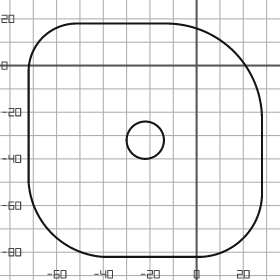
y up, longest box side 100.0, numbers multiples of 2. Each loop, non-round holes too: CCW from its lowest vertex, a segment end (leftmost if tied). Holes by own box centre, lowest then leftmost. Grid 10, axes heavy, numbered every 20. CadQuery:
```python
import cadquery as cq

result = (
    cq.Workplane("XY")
    .moveTo(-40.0, -82.0)
    .lineTo(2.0, -82.0)
    .threePointArc((20.0, -74.0), (28.0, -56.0))
    .lineTo(28.0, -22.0)
    .threePointArc((16.0, 6.0), (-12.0, 18.0))
    .lineTo(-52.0, 18.0)
    .threePointArc((-66.0, 12.0), (-72.0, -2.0))
    .lineTo(-72.0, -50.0)
    .threePointArc((-62.0, -72.0), (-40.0, -82.0))
    .close()
    .moveTo(-22.0, -32.0)
    .circle(8.0)
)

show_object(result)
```